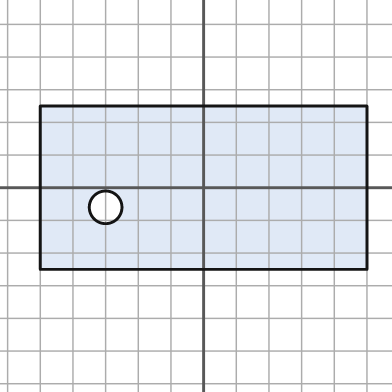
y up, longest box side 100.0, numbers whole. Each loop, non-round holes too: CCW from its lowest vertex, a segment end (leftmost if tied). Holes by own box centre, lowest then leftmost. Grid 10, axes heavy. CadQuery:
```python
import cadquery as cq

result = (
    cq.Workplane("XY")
    .moveTo(-50.0, -25.0)
    .lineTo(50.0, -25.0)
    .lineTo(50.0, 25.0)
    .lineTo(-50.0, 25.0)
    .close()
    .moveTo(-30.0, -6.0)
    .circle(5.0)
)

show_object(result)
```